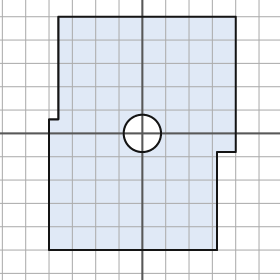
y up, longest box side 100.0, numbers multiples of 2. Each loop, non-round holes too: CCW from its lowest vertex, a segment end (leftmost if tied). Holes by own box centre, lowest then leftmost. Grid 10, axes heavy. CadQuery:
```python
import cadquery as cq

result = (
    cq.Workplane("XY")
    .moveTo(-40.0, -50.0)
    .lineTo(32.0, -50.0)
    .lineTo(32.0, -8.0)
    .lineTo(40.0, -8.0)
    .lineTo(40.0, 50.0)
    .lineTo(-36.0, 50.0)
    .lineTo(-36.0, 6.0)
    .lineTo(-40.0, 6.0)
    .close()
    .moveTo(0.0, 0.0)
    .circle(8.0)
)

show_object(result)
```